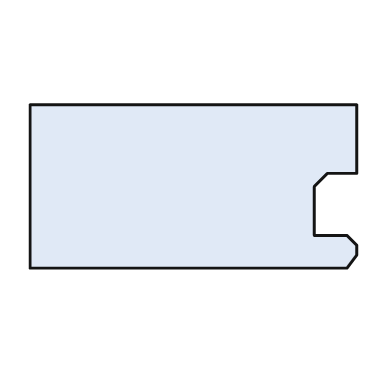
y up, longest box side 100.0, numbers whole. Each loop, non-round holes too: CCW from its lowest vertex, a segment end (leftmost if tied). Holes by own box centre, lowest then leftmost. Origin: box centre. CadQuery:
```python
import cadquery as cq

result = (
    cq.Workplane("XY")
    .moveTo(-50.0, -25.0)
    .lineTo(47.0, -25.0)
    .lineTo(50.0, -21.0)
    .lineTo(50.0, -18.0)
    .lineTo(47.0, -15.0)
    .lineTo(37.0, -15.0)
    .lineTo(37.0, 0.0)
    .lineTo(41.0, 4.0)
    .lineTo(50.0, 4.0)
    .lineTo(50.0, 25.0)
    .lineTo(-50.0, 25.0)
    .close()
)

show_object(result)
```